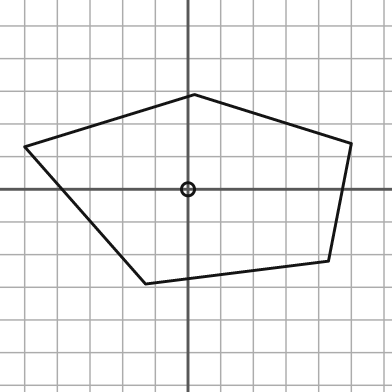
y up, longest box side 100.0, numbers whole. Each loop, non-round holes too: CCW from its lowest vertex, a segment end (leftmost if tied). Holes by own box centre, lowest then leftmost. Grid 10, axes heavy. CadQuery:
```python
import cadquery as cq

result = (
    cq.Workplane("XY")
    .moveTo(-13.0, -29.0)
    .lineTo(43.0, -22.0)
    .lineTo(50.0, 14.0)
    .lineTo(2.0, 29.0)
    .lineTo(-50.0, 13.0)
    .close()
    .moveTo(0.0, 0.0)
    .circle(2.0)
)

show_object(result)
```